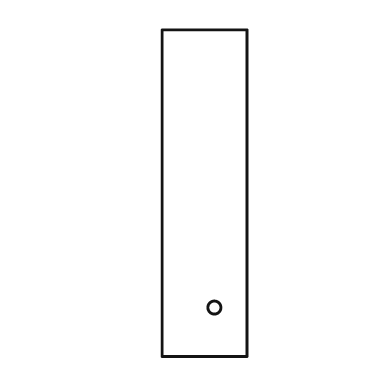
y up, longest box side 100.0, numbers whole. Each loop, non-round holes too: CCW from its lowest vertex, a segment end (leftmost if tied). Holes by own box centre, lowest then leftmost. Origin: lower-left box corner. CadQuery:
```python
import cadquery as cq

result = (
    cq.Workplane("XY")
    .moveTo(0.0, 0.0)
    .lineTo(26.0, 0.0)
    .lineTo(26.0, 100.0)
    .lineTo(0.0, 100.0)
    .close()
    .moveTo(16.0, 15.0)
    .circle(2.0)
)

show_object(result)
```